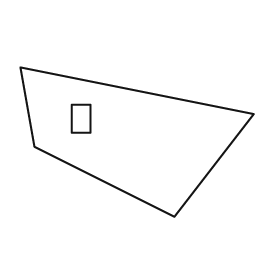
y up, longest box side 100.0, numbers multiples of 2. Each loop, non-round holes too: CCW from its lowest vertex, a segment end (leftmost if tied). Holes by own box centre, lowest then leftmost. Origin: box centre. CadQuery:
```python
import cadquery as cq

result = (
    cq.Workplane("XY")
    .moveTo(16.0, -32.0)
    .lineTo(50.0, 12.0)
    .lineTo(-50.0, 32.0)
    .lineTo(-44.0, -2.0)
    .close()
    .moveTo(-28.0, 4.0)
    .lineTo(-20.0, 4.0)
    .lineTo(-20.0, 16.0)
    .lineTo(-28.0, 16.0)
    .close()
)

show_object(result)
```